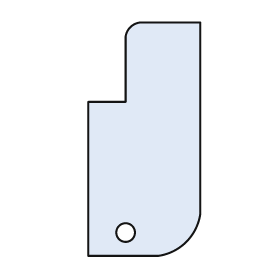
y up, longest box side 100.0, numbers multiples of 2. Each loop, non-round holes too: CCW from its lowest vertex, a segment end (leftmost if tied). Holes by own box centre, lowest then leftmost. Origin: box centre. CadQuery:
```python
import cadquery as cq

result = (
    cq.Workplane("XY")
    .moveTo(-24.0, -50.0)
    .lineTo(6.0, -50.0)
    .threePointArc((18.0, -44.0), (24.0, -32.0))
    .lineTo(24.0, 50.0)
    .lineTo(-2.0, 50.0)
    .threePointArc((-6.0, 48.0), (-8.0, 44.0))
    .lineTo(-8.0, 16.0)
    .lineTo(-24.0, 16.0)
    .close()
    .moveTo(-8.0, -40.0)
    .circle(4.0)
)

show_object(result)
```